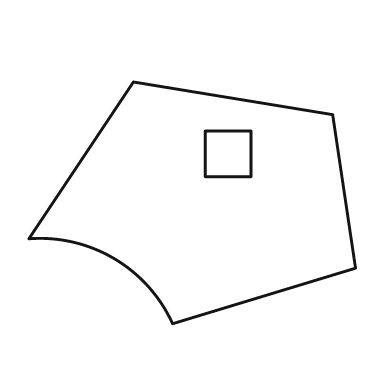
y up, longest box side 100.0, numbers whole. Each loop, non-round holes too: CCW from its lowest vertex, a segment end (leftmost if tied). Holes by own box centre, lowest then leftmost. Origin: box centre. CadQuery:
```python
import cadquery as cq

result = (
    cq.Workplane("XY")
    .moveTo(-6.0, -37.0)
    .lineTo(50.0, -20.0)
    .lineTo(43.0, 27.0)
    .lineTo(-18.0, 37.0)
    .lineTo(-50.0, -11.0)
    .threePointArc((-24.0, -17.0), (-6.0, -37.0))
    .close()
    .moveTo(4.0, 8.0)
    .lineTo(18.0, 8.0)
    .lineTo(18.0, 22.0)
    .lineTo(4.0, 22.0)
    .close()
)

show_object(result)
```